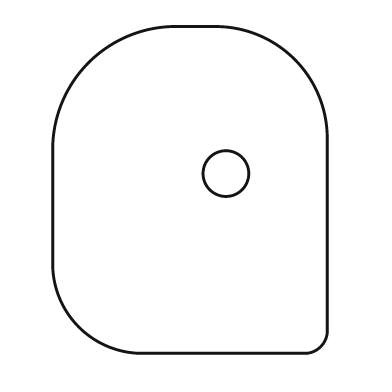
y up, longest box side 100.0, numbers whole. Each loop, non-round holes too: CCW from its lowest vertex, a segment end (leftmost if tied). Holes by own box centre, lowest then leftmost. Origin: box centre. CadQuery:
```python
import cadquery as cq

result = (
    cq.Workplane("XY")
    .moveTo(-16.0, -50.0)
    .lineTo(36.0, -50.0)
    .threePointArc((40.0, -48.0), (42.0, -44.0))
    .lineTo(42.0, 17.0)
    .threePointArc((32.0, 40.0), (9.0, 50.0))
    .lineTo(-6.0, 50.0)
    .threePointArc((-31.0, 39.0), (-42.0, 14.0))
    .lineTo(-42.0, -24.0)
    .threePointArc((-34.0, -42.0), (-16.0, -50.0))
    .close()
    .moveTo(11.0, 5.0)
    .circle(7.0)
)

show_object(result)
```